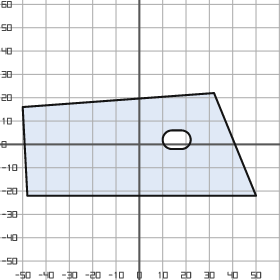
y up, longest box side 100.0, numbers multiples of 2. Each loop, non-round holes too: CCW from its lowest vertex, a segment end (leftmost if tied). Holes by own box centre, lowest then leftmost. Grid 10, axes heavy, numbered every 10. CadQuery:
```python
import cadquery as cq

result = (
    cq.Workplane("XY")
    .moveTo(-48.0, -22.0)
    .lineTo(50.0, -22.0)
    .lineTo(32.0, 22.0)
    .lineTo(-50.0, 16.0)
    .close()
    .moveTo(14.0, -2.0)
    .lineTo(18.0, -2.0)
    .threePointArc((22.0, 2.0), (18.0, 6.0))
    .lineTo(14.0, 6.0)
    .threePointArc((10.0, 2.0), (14.0, -2.0))
    .close()
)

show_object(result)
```